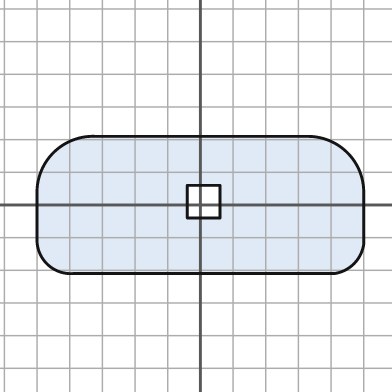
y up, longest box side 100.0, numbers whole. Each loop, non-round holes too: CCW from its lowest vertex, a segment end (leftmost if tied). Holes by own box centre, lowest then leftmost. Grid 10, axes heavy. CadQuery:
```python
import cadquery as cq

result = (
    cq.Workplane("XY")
    .moveTo(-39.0, -21.0)
    .lineTo(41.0, -21.0)
    .threePointArc((47.0, -18.0), (50.0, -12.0))
    .lineTo(50.0, 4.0)
    .threePointArc((45.0, 16.0), (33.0, 21.0))
    .lineTo(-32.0, 21.0)
    .threePointArc((-45.0, 16.0), (-50.0, 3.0))
    .lineTo(-50.0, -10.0)
    .threePointArc((-47.0, -18.0), (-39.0, -21.0))
    .close()
    .moveTo(-4.0, -4.0)
    .lineTo(6.0, -4.0)
    .lineTo(6.0, 6.0)
    .lineTo(-4.0, 6.0)
    .close()
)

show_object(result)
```